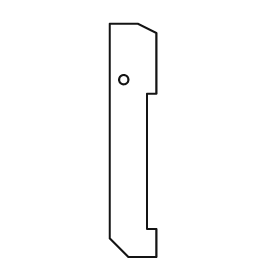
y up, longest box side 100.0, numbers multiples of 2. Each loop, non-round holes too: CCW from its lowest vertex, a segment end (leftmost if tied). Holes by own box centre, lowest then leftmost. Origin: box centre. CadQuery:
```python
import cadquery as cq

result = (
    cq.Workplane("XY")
    .moveTo(-2.0, -50.0)
    .lineTo(10.0, -50.0)
    .lineTo(10.0, -38.0)
    .lineTo(6.0, -38.0)
    .lineTo(6.0, 20.0)
    .lineTo(10.0, 20.0)
    .lineTo(10.0, 46.0)
    .lineTo(2.0, 50.0)
    .lineTo(-10.0, 50.0)
    .lineTo(-10.0, -42.0)
    .close()
    .moveTo(-4.0, 26.0)
    .circle(2.0)
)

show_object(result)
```